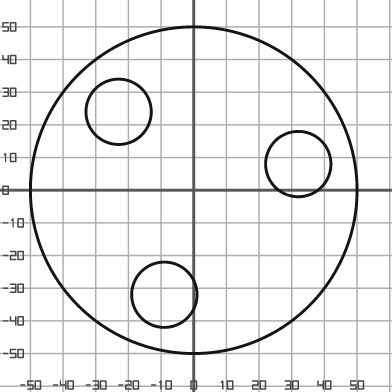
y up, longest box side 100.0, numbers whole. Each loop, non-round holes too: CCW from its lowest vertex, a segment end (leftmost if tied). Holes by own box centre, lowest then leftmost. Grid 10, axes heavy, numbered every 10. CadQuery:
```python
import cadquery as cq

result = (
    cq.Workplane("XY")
    .moveTo(0.0, 0.0)
    .circle(50.0)
    .moveTo(-9.0, -32.0)
    .circle(10.0)
    .moveTo(32.0, 8.0)
    .circle(10.0)
    .moveTo(-23.0, 24.0)
    .circle(10.0)
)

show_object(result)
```